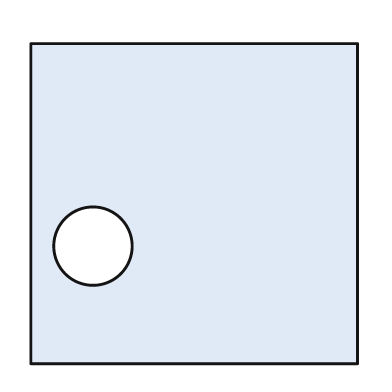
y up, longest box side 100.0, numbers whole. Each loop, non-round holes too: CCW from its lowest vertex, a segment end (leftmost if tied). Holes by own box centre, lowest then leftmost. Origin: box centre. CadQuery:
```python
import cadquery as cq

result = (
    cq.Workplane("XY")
    .moveTo(-50.0, -49.0)
    .lineTo(50.0, -49.0)
    .lineTo(50.0, 49.0)
    .lineTo(-50.0, 49.0)
    .close()
    .moveTo(-31.0, -13.0)
    .circle(12.0)
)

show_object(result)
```